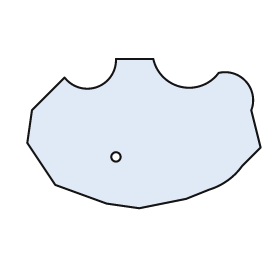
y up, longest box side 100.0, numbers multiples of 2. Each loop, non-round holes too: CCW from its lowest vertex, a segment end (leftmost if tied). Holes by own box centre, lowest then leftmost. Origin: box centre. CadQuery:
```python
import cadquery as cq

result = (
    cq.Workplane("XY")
    .moveTo(-2.0, -32.0)
    .lineTo(18.0, -28.0)
    .lineTo(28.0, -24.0)
    .threePointArc((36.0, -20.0), (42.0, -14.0))
    .lineTo(50.0, -6.0)
    .lineTo(46.0, 10.0)
    .threePointArc((44.0, 22.0), (32.0, 26.0))
    .threePointArc((16.0, 20.0), (4.0, 32.0))
    .lineTo(-12.0, 32.0)
    .threePointArc((-20.0, 20.0), (-34.0, 24.0))
    .lineTo(-48.0, 10.0)
    .lineTo(-50.0, -4.0)
    .lineTo(-38.0, -22.0)
    .lineTo(-16.0, -30.0)
    .close()
    .moveTo(-12.0, -10.0)
    .circle(2.0)
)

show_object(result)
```